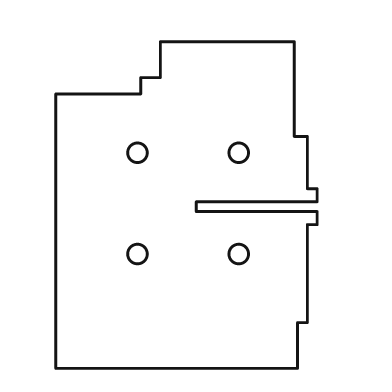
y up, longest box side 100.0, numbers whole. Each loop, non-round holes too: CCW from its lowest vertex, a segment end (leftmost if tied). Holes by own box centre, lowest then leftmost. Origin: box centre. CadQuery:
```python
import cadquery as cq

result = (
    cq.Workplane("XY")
    .moveTo(-40.0, -50.0)
    .lineTo(34.0, -50.0)
    .lineTo(34.0, -36.0)
    .lineTo(37.0, -36.0)
    .lineTo(37.0, -6.0)
    .lineTo(40.0, -6.0)
    .lineTo(40.0, -2.0)
    .lineTo(3.0, -2.0)
    .lineTo(3.0, 1.0)
    .lineTo(40.0, 1.0)
    .lineTo(40.0, 5.0)
    .lineTo(37.0, 5.0)
    .lineTo(37.0, 21.0)
    .lineTo(33.0, 21.0)
    .lineTo(33.0, 50.0)
    .lineTo(-8.0, 50.0)
    .lineTo(-8.0, 39.0)
    .lineTo(-14.0, 39.0)
    .lineTo(-14.0, 34.0)
    .lineTo(-40.0, 34.0)
    .close()
    .moveTo(-15.0, -15.0)
    .circle(3.0)
    .moveTo(16.0, -15.0)
    .circle(3.0)
    .moveTo(-15.0, 16.0)
    .circle(3.0)
    .moveTo(16.0, 16.0)
    .circle(3.0)
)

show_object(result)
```